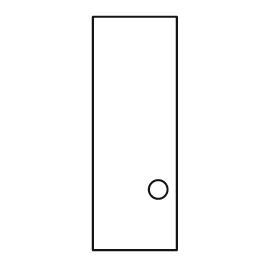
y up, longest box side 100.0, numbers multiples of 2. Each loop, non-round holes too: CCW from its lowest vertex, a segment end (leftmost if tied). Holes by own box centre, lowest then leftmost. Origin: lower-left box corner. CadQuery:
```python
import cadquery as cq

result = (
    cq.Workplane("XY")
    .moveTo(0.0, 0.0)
    .lineTo(36.0, 0.0)
    .lineTo(36.0, 100.0)
    .lineTo(0.0, 100.0)
    .close()
    .moveTo(28.0, 26.0)
    .circle(4.0)
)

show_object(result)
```